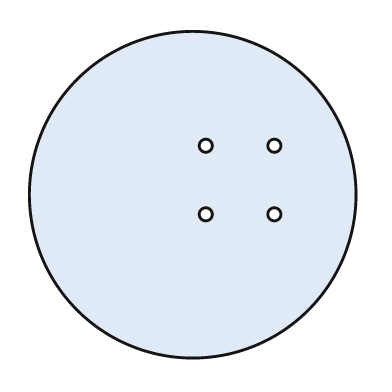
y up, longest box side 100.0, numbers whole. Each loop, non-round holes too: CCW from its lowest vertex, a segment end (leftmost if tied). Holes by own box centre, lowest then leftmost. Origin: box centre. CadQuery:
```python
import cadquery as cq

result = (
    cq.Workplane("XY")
    .moveTo(0.0, 0.0)
    .circle(50.0)
    .moveTo(4.0, -6.0)
    .circle(2.0)
    .moveTo(25.0, -6.0)
    .circle(2.0)
    .moveTo(4.0, 15.0)
    .circle(2.0)
    .moveTo(25.0, 15.0)
    .circle(2.0)
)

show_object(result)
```